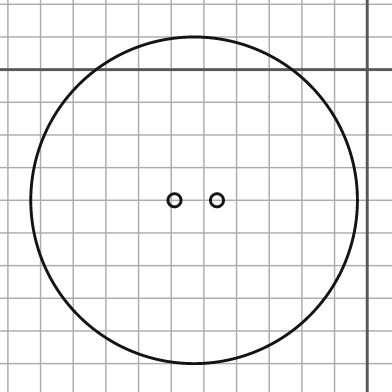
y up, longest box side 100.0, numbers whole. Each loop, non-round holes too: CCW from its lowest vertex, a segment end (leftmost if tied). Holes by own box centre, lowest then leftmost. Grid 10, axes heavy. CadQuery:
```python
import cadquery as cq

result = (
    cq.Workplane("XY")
    .moveTo(-53.0, -40.0)
    .circle(50.0)
    .moveTo(-59.0, -40.0)
    .circle(2.0)
    .moveTo(-46.0, -40.0)
    .circle(2.0)
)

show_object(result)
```